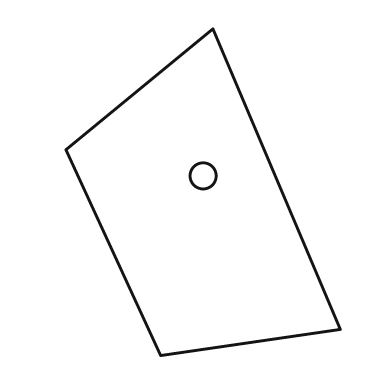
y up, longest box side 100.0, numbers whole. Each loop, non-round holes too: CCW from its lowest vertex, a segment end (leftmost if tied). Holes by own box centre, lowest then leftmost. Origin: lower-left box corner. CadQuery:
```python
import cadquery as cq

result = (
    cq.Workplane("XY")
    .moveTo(29.0, 0.0)
    .lineTo(84.0, 8.0)
    .lineTo(45.0, 100.0)
    .lineTo(0.0, 63.0)
    .close()
    .moveTo(42.0, 55.0)
    .circle(4.0)
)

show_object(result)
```